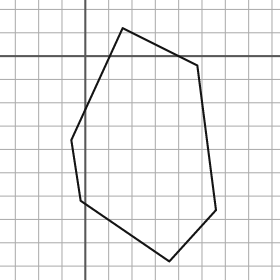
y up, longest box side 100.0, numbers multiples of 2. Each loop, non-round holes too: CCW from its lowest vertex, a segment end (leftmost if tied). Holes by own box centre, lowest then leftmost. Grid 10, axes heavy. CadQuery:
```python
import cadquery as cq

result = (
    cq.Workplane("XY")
    .moveTo(36.0, -88.0)
    .lineTo(56.0, -66.0)
    .lineTo(48.0, -4.0)
    .lineTo(16.0, 12.0)
    .lineTo(-6.0, -36.0)
    .lineTo(-2.0, -62.0)
    .close()
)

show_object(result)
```